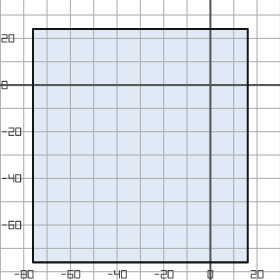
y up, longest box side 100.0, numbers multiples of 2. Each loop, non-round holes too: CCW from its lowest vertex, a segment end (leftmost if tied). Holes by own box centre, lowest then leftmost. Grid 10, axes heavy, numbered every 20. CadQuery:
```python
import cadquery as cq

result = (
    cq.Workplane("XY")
    .moveTo(-76.0, -76.0)
    .lineTo(16.0, -76.0)
    .lineTo(16.0, 24.0)
    .lineTo(-76.0, 24.0)
    .close()
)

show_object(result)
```